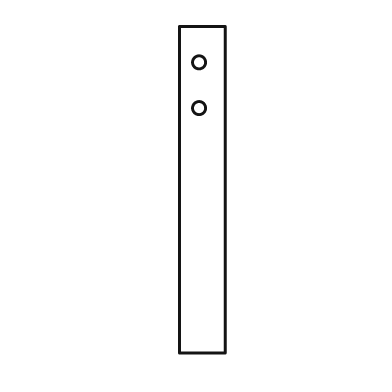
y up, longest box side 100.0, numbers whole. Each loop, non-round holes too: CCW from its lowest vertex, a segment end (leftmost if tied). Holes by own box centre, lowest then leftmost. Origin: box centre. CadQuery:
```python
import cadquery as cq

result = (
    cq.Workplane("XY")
    .moveTo(-7.0, -50.0)
    .lineTo(7.0, -50.0)
    .lineTo(7.0, 50.0)
    .lineTo(-7.0, 50.0)
    .close()
    .moveTo(-1.0, 25.0)
    .circle(2.0)
    .moveTo(-1.0, 39.0)
    .circle(2.0)
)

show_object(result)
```